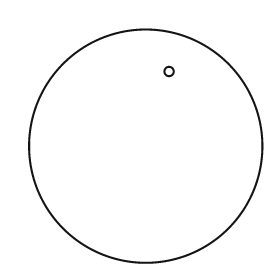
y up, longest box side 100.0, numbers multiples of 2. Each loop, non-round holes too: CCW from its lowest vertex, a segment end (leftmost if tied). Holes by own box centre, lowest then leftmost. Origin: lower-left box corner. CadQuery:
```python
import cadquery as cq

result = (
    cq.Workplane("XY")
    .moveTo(50.0, 50.0)
    .circle(50.0)
    .moveTo(60.0, 82.0)
    .circle(2.0)
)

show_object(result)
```